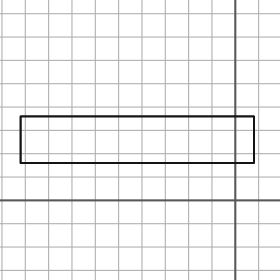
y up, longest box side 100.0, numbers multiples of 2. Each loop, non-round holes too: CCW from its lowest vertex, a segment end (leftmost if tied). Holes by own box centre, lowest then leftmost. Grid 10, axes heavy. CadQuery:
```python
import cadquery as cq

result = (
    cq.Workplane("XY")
    .moveTo(-92.0, 16.0)
    .lineTo(8.0, 16.0)
    .lineTo(8.0, 36.0)
    .lineTo(-92.0, 36.0)
    .close()
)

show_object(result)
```